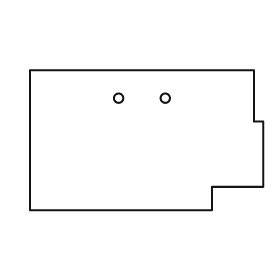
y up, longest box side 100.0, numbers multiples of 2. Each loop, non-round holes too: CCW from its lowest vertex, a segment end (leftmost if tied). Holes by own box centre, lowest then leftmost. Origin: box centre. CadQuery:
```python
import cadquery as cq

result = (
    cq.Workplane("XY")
    .moveTo(-50.0, -30.0)
    .lineTo(28.0, -30.0)
    .lineTo(28.0, -20.0)
    .lineTo(50.0, -20.0)
    .lineTo(50.0, 8.0)
    .lineTo(46.0, 8.0)
    .lineTo(46.0, 30.0)
    .lineTo(-50.0, 30.0)
    .close()
    .moveTo(-12.0, 18.0)
    .circle(2.0)
    .moveTo(8.0, 18.0)
    .circle(2.0)
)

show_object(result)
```